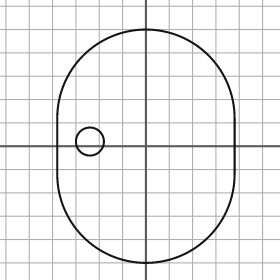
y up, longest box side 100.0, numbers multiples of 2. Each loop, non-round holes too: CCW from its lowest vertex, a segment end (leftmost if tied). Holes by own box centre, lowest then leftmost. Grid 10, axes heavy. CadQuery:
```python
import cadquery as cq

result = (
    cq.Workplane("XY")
    .moveTo(-38.0, -12.0)
    .threePointArc((0.0, -50.0), (38.0, -12.0))
    .lineTo(38.0, 12.0)
    .threePointArc((0.0, 50.0), (-38.0, 12.0))
    .close()
    .moveTo(-24.0, 2.0)
    .circle(6.0)
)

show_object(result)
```